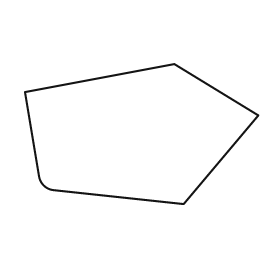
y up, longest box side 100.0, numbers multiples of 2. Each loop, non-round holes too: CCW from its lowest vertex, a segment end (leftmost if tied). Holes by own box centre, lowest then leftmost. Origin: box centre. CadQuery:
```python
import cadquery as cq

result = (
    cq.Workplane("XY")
    .moveTo(18.0, -30.0)
    .lineTo(50.0, 8.0)
    .lineTo(14.0, 30.0)
    .lineTo(-50.0, 18.0)
    .lineTo(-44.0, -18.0)
    .threePointArc((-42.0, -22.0), (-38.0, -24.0))
    .close()
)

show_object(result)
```